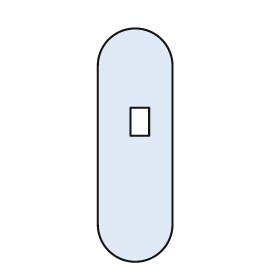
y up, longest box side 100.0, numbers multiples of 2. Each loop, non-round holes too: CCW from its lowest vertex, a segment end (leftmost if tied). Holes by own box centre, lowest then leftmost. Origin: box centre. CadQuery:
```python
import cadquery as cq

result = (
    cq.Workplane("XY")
    .moveTo(-16.0, -34.0)
    .threePointArc((0.0, -50.0), (16.0, -34.0))
    .lineTo(16.0, 34.0)
    .threePointArc((0.0, 50.0), (-16.0, 34.0))
    .close()
    .moveTo(-2.0, 4.0)
    .lineTo(6.0, 4.0)
    .lineTo(6.0, 16.0)
    .lineTo(-2.0, 16.0)
    .close()
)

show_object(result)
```